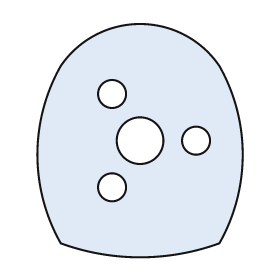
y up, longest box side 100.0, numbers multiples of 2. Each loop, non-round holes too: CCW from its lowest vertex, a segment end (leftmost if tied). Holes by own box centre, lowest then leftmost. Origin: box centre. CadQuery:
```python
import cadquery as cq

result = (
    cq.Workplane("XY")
    .moveTo(-34.0, -44.0)
    .threePointArc((0.0, -50.0), (34.0, -44.0))
    .threePointArc((44.0, -6.0), (34.0, 32.0))
    .threePointArc((0.0, 50.0), (-34.0, 32.0))
    .threePointArc((-44.0, -6.0), (-34.0, -44.0))
    .close()
    .moveTo(-12.0, -20.0)
    .circle(6.0)
    .moveTo(0.0, 0.0)
    .circle(10.0)
    .moveTo(24.0, 0.0)
    .circle(6.0)
    .moveTo(-12.0, 20.0)
    .circle(6.0)
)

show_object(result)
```